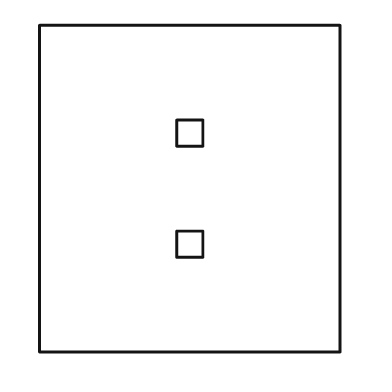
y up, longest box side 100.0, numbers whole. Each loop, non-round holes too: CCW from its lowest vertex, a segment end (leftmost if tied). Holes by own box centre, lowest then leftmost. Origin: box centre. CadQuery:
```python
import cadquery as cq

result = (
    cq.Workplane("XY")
    .moveTo(-46.0, -50.0)
    .lineTo(46.0, -50.0)
    .lineTo(46.0, 50.0)
    .lineTo(-46.0, 50.0)
    .close()
    .moveTo(-4.0, -21.0)
    .lineTo(4.0, -21.0)
    .lineTo(4.0, -13.0)
    .lineTo(-4.0, -13.0)
    .close()
    .moveTo(-4.0, 13.0)
    .lineTo(4.0, 13.0)
    .lineTo(4.0, 21.0)
    .lineTo(-4.0, 21.0)
    .close()
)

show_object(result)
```